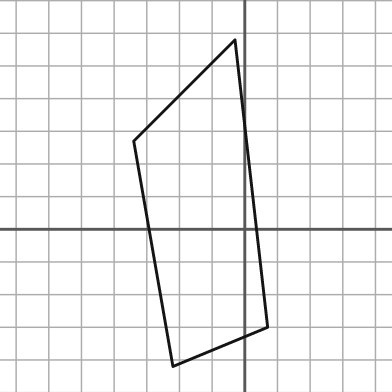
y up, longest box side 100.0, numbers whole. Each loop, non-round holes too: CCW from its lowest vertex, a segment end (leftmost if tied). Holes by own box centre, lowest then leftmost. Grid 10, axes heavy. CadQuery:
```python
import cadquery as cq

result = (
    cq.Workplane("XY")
    .moveTo(-22.0, -42.0)
    .lineTo(7.0, -30.0)
    .lineTo(-3.0, 58.0)
    .lineTo(-34.0, 27.0)
    .close()
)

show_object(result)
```